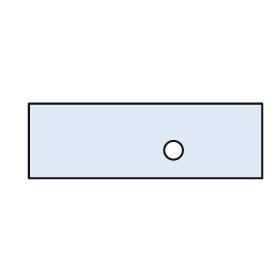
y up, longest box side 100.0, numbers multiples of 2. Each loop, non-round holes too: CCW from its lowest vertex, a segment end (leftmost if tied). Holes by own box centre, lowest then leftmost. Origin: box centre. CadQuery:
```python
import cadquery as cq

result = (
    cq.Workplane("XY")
    .moveTo(-50.0, -16.0)
    .lineTo(50.0, -16.0)
    .lineTo(50.0, 16.0)
    .lineTo(-50.0, 16.0)
    .close()
    .moveTo(12.0, -4.0)
    .circle(4.0)
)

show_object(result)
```